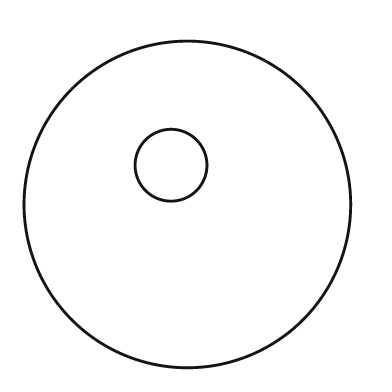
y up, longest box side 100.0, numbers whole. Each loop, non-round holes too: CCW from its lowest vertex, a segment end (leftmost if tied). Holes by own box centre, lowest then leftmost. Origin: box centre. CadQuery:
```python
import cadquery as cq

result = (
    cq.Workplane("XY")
    .moveTo(0.0, 0.0)
    .circle(50.0)
    .moveTo(-5.0, 12.0)
    .circle(11.0)
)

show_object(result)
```